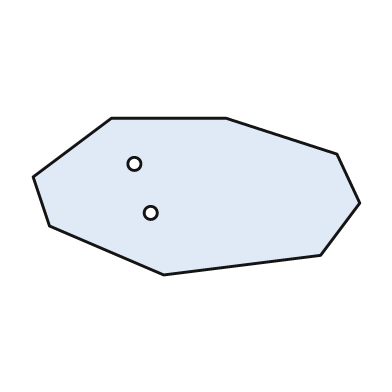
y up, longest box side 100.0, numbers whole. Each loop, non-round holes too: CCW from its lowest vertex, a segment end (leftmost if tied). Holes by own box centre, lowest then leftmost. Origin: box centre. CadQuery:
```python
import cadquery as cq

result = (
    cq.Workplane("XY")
    .moveTo(-10.0, -24.0)
    .lineTo(38.0, -18.0)
    .lineTo(50.0, -2.0)
    .lineTo(43.0, 13.0)
    .lineTo(9.0, 24.0)
    .lineTo(-26.0, 24.0)
    .lineTo(-50.0, 6.0)
    .lineTo(-45.0, -9.0)
    .close()
    .moveTo(-14.0, -5.0)
    .circle(2.0)
    .moveTo(-19.0, 10.0)
    .circle(2.0)
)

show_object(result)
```